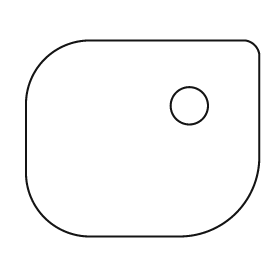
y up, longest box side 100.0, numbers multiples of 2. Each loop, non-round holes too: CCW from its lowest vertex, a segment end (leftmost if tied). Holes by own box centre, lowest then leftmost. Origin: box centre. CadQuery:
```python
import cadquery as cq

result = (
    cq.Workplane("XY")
    .moveTo(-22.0, -42.0)
    .lineTo(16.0, -42.0)
    .threePointArc((40.0, -32.0), (50.0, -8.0))
    .lineTo(50.0, 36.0)
    .threePointArc((48.0, 40.0), (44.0, 42.0))
    .lineTo(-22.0, 42.0)
    .threePointArc((-42.0, 34.0), (-50.0, 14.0))
    .lineTo(-50.0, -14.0)
    .threePointArc((-42.0, -34.0), (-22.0, -42.0))
    .close()
    .moveTo(20.0, 14.0)
    .circle(8.0)
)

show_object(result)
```